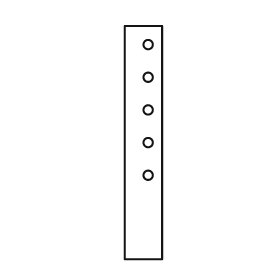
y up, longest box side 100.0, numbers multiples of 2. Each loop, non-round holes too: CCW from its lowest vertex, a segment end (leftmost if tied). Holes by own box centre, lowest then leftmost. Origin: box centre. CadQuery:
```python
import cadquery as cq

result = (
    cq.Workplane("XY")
    .moveTo(-8.0, -50.0)
    .lineTo(8.0, -50.0)
    .lineTo(8.0, 50.0)
    .lineTo(-8.0, 50.0)
    .close()
    .moveTo(2.0, -14.0)
    .circle(2.0)
    .moveTo(2.0, 0.0)
    .circle(2.0)
    .moveTo(2.0, 14.0)
    .circle(2.0)
    .moveTo(2.0, 28.0)
    .circle(2.0)
    .moveTo(2.0, 42.0)
    .circle(2.0)
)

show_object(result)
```